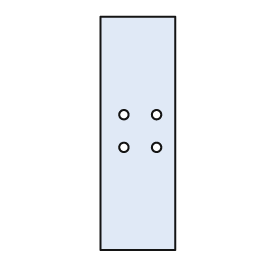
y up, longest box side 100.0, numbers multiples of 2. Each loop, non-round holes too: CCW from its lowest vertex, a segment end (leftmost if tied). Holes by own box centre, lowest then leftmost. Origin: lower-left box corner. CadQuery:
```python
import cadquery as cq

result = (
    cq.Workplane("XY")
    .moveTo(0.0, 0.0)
    .lineTo(32.0, 0.0)
    .lineTo(32.0, 100.0)
    .lineTo(0.0, 100.0)
    .close()
    .moveTo(10.0, 44.0)
    .circle(2.0)
    .moveTo(24.0, 44.0)
    .circle(2.0)
    .moveTo(10.0, 58.0)
    .circle(2.0)
    .moveTo(24.0, 58.0)
    .circle(2.0)
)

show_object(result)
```